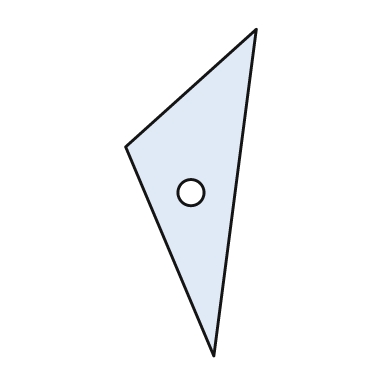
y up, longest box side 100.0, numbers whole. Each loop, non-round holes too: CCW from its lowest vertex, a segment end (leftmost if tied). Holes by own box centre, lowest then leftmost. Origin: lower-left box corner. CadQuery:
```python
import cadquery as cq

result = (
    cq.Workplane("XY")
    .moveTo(27.0, 0.0)
    .lineTo(40.0, 100.0)
    .lineTo(0.0, 64.0)
    .close()
    .moveTo(20.0, 50.0)
    .circle(4.0)
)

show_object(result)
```